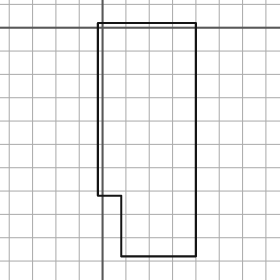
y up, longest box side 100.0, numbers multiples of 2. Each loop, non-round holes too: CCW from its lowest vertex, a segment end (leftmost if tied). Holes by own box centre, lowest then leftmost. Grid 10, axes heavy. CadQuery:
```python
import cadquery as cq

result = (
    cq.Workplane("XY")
    .moveTo(8.0, -98.0)
    .lineTo(40.0, -98.0)
    .lineTo(40.0, 2.0)
    .lineTo(-2.0, 2.0)
    .lineTo(-2.0, -72.0)
    .lineTo(8.0, -72.0)
    .close()
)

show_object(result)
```